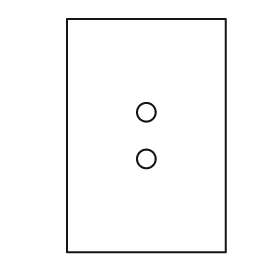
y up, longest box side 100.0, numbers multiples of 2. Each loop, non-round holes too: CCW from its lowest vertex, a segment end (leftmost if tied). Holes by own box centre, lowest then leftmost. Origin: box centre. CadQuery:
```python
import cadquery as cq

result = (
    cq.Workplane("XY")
    .moveTo(-34.0, -50.0)
    .lineTo(34.0, -50.0)
    .lineTo(34.0, 50.0)
    .lineTo(-34.0, 50.0)
    .close()
    .moveTo(0.0, -10.0)
    .circle(4.0)
    .moveTo(0.0, 10.0)
    .circle(4.0)
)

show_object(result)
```